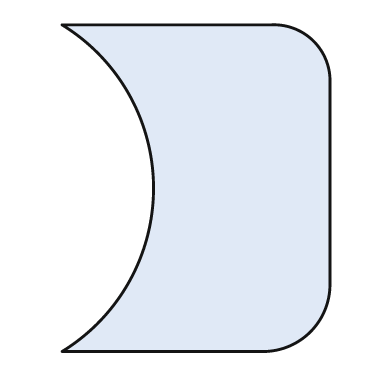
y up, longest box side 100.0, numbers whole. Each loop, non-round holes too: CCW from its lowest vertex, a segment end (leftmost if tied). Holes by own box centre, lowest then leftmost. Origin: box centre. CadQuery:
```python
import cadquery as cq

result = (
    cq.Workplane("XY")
    .moveTo(-41.0, -50.0)
    .lineTo(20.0, -50.0)
    .threePointArc((35.0, -44.0), (41.0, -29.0))
    .lineTo(41.0, 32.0)
    .threePointArc((36.0, 45.0), (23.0, 50.0))
    .lineTo(-41.0, 50.0)
    .threePointArc((-13.0, 0.0), (-41.0, -50.0))
    .close()
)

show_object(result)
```